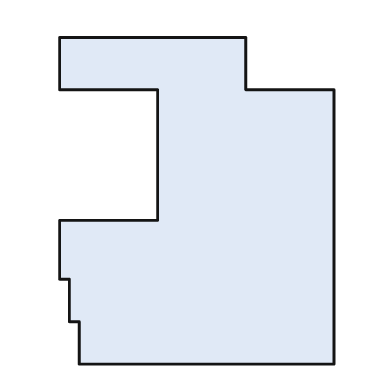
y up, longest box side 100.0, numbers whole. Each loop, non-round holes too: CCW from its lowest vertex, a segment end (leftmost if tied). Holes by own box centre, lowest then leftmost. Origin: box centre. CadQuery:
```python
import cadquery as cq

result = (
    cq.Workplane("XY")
    .moveTo(-36.0, -50.0)
    .lineTo(42.0, -50.0)
    .lineTo(42.0, 34.0)
    .lineTo(15.0, 34.0)
    .lineTo(15.0, 50.0)
    .lineTo(-42.0, 50.0)
    .lineTo(-42.0, 34.0)
    .lineTo(-12.0, 34.0)
    .lineTo(-12.0, -6.0)
    .lineTo(-42.0, -6.0)
    .lineTo(-42.0, -24.0)
    .lineTo(-39.0, -24.0)
    .lineTo(-39.0, -37.0)
    .lineTo(-36.0, -37.0)
    .close()
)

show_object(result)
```